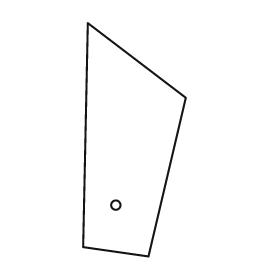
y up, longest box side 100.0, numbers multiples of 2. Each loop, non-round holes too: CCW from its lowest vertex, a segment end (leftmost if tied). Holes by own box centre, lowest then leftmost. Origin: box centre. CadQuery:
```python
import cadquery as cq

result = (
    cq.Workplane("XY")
    .moveTo(6.0, -50.0)
    .lineTo(22.0, 18.0)
    .lineTo(-20.0, 50.0)
    .lineTo(-22.0, -46.0)
    .close()
    .moveTo(-8.0, -28.0)
    .circle(2.0)
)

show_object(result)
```